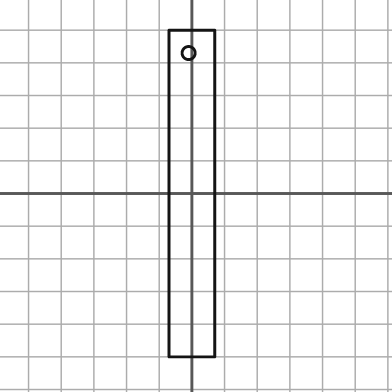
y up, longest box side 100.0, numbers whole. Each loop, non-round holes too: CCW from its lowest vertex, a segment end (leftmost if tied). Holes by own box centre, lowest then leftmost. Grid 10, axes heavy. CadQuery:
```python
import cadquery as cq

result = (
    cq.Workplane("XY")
    .moveTo(-7.0, -50.0)
    .lineTo(7.0, -50.0)
    .lineTo(7.0, 50.0)
    .lineTo(-7.0, 50.0)
    .close()
    .moveTo(-1.0, 43.0)
    .circle(2.0)
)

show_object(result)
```